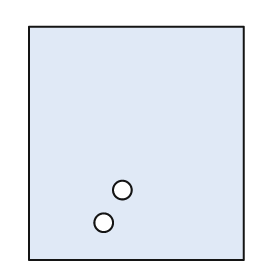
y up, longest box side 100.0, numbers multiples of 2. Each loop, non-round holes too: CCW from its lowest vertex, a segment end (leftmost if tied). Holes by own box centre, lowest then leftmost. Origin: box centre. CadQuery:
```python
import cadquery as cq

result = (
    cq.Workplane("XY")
    .moveTo(-46.0, -50.0)
    .lineTo(46.0, -50.0)
    .lineTo(46.0, 50.0)
    .lineTo(-46.0, 50.0)
    .close()
    .moveTo(-14.0, -34.0)
    .circle(4.0)
    .moveTo(-6.0, -20.0)
    .circle(4.0)
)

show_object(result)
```